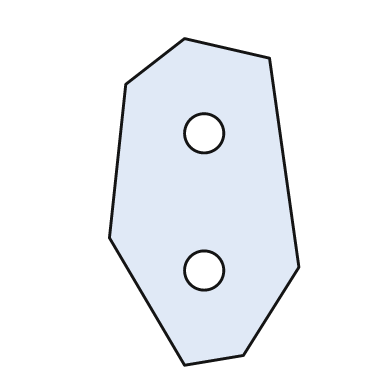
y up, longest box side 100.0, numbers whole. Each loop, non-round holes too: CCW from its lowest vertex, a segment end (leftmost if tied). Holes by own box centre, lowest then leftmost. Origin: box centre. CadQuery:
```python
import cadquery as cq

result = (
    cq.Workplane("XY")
    .moveTo(-6.0, -50.0)
    .lineTo(12.0, -47.0)
    .lineTo(29.0, -20.0)
    .lineTo(20.0, 44.0)
    .lineTo(-6.0, 50.0)
    .lineTo(-24.0, 36.0)
    .lineTo(-29.0, -11.0)
    .close()
    .moveTo(0.0, -21.0)
    .circle(6.0)
    .moveTo(0.0, 21.0)
    .circle(6.0)
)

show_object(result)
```